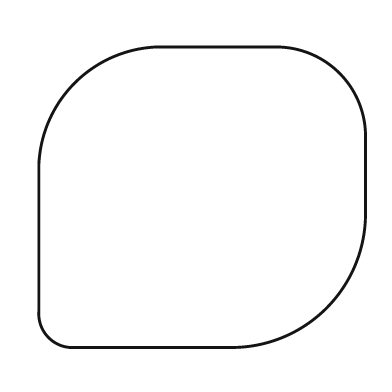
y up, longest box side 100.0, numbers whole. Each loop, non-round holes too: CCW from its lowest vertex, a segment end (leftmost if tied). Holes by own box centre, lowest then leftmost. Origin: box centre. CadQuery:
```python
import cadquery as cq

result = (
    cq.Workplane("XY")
    .moveTo(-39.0, -46.0)
    .lineTo(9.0, -46.0)
    .threePointArc((38.0, -34.0), (50.0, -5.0))
    .lineTo(50.0, 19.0)
    .threePointArc((42.0, 38.0), (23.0, 46.0))
    .lineTo(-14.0, 46.0)
    .threePointArc((-39.0, 35.0), (-50.0, 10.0))
    .lineTo(-50.0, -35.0)
    .threePointArc((-47.0, -43.0), (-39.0, -46.0))
    .close()
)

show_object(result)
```